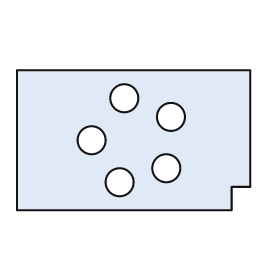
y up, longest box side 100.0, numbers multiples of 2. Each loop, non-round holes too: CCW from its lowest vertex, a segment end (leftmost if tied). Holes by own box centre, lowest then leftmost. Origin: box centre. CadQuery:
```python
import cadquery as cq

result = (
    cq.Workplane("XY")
    .moveTo(-50.0, -30.0)
    .lineTo(42.0, -30.0)
    .lineTo(42.0, -20.0)
    .lineTo(50.0, -20.0)
    .lineTo(50.0, 30.0)
    .lineTo(-50.0, 30.0)
    .close()
    .moveTo(-6.0, -18.0)
    .circle(6.0)
    .moveTo(14.0, -12.0)
    .circle(6.0)
    .moveTo(-18.0, 0.0)
    .circle(6.0)
    .moveTo(16.0, 10.0)
    .circle(6.0)
    .moveTo(-4.0, 18.0)
    .circle(6.0)
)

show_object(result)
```